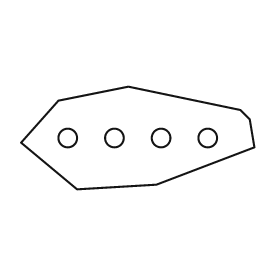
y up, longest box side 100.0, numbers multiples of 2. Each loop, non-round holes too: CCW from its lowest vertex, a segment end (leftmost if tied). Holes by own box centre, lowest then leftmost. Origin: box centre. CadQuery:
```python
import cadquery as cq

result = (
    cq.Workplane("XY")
    .moveTo(-26.0, -22.0)
    .lineTo(8.0, -20.0)
    .lineTo(50.0, -4.0)
    .lineTo(48.0, 8.0)
    .lineTo(44.0, 12.0)
    .lineTo(-4.0, 22.0)
    .lineTo(-34.0, 16.0)
    .lineTo(-50.0, -2.0)
    .close()
    .moveTo(-30.0, 0.0)
    .circle(4.0)
    .moveTo(-10.0, 0.0)
    .circle(4.0)
    .moveTo(10.0, 0.0)
    .circle(4.0)
    .moveTo(30.0, 0.0)
    .circle(4.0)
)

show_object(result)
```